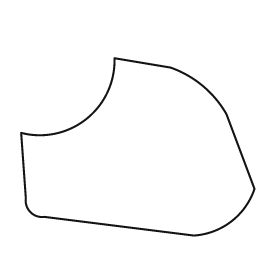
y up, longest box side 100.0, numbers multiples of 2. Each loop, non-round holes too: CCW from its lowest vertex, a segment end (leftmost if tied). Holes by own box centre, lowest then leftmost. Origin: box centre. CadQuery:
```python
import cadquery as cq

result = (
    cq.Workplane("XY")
    .moveTo(24.0, -38.0)
    .threePointArc((40.0, -32.0), (50.0, -18.0))
    .lineTo(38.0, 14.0)
    .threePointArc((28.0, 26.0), (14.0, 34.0))
    .lineTo(-10.0, 38.0)
    .threePointArc((-22.0, 12.0), (-50.0, 6.0))
    .lineTo(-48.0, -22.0)
    .threePointArc((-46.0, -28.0), (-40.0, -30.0))
    .close()
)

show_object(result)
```